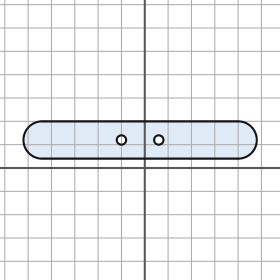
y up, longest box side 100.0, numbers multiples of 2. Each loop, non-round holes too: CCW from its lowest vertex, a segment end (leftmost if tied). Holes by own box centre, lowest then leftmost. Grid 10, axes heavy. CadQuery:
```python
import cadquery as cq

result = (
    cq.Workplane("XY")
    .moveTo(-44.0, 4.0)
    .lineTo(40.0, 4.0)
    .threePointArc((48.0, 12.0), (40.0, 20.0))
    .lineTo(-44.0, 20.0)
    .threePointArc((-52.0, 12.0), (-44.0, 4.0))
    .close()
    .moveTo(-10.0, 12.0)
    .circle(2.0)
    .moveTo(6.0, 12.0)
    .circle(2.0)
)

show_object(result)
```